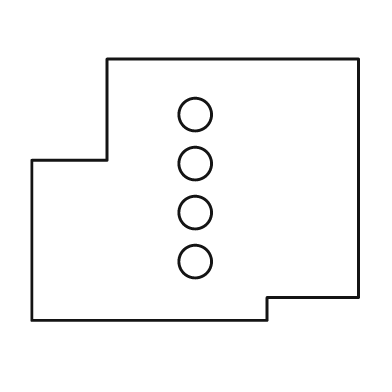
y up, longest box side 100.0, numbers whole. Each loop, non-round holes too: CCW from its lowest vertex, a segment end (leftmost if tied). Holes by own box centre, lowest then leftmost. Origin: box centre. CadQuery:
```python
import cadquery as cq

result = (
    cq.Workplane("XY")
    .moveTo(-50.0, -40.0)
    .lineTo(22.0, -40.0)
    .lineTo(22.0, -33.0)
    .lineTo(50.0, -33.0)
    .lineTo(50.0, 40.0)
    .lineTo(-27.0, 40.0)
    .lineTo(-27.0, 9.0)
    .lineTo(-50.0, 9.0)
    .close()
    .moveTo(0.0, -22.0)
    .circle(5.0)
    .moveTo(0.0, -7.0)
    .circle(5.0)
    .moveTo(0.0, 8.0)
    .circle(5.0)
    .moveTo(0.0, 23.0)
    .circle(5.0)
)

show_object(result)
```